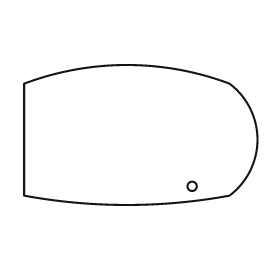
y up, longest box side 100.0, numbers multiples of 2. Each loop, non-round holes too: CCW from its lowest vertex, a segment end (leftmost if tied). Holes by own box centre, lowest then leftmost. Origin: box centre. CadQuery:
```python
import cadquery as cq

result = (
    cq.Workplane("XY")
    .moveTo(-50.0, -26.0)
    .threePointArc((-6.0, -30.0), (38.0, -26.0))
    .threePointArc((50.0, -2.0), (38.0, 22.0))
    .threePointArc((-6.0, 30.0), (-50.0, 22.0))
    .close()
    .moveTo(22.0, -22.0)
    .circle(2.0)
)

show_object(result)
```